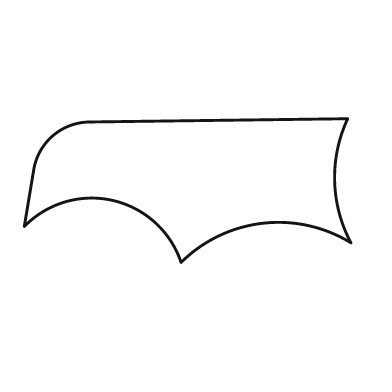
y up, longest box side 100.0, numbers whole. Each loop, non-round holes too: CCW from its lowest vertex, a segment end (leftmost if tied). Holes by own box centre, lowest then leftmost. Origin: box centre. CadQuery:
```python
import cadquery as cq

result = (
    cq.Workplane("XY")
    .moveTo(-2.0, -22.0)
    .threePointArc((23.0, -10.0), (50.0, -16.0))
    .threePointArc((45.0, 3.0), (49.0, 22.0))
    .lineTo(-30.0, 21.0)
    .threePointArc((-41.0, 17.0), (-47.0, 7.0))
    .lineTo(-50.0, -11.0)
    .threePointArc((-23.0, -3.0), (-2.0, -22.0))
    .close()
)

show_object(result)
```